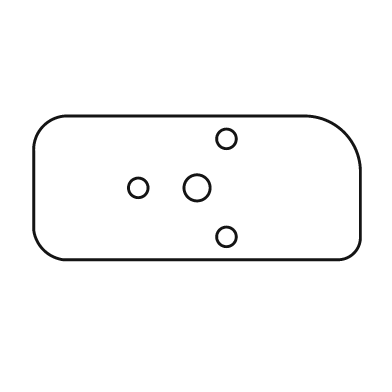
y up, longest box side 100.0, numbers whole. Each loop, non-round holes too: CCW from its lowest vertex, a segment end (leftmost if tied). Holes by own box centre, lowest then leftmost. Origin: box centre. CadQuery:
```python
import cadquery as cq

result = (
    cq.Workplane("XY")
    .moveTo(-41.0, -22.0)
    .lineTo(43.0, -22.0)
    .threePointArc((48.0, -20.0), (50.0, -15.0))
    .lineTo(50.0, 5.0)
    .threePointArc((45.0, 17.0), (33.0, 22.0))
    .lineTo(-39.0, 22.0)
    .threePointArc((-47.0, 19.0), (-50.0, 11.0))
    .lineTo(-50.0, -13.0)
    .threePointArc((-47.0, -19.0), (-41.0, -22.0))
    .close()
    .moveTo(9.0, -15.0)
    .circle(3.0)
    .moveTo(-18.0, 0.0)
    .circle(3.0)
    .moveTo(0.0, 0.0)
    .circle(4.0)
    .moveTo(9.0, 15.0)
    .circle(3.0)
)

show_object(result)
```